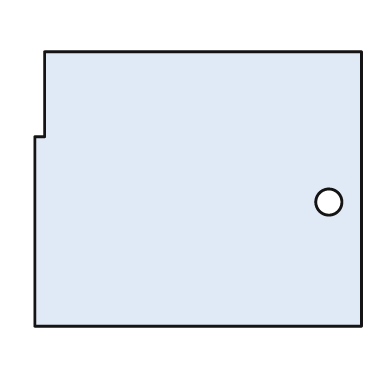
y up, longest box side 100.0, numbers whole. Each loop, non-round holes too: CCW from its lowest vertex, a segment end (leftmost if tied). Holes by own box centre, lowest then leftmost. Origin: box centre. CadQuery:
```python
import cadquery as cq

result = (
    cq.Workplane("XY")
    .moveTo(-50.0, -42.0)
    .lineTo(50.0, -42.0)
    .lineTo(50.0, 42.0)
    .lineTo(-47.0, 42.0)
    .lineTo(-47.0, 16.0)
    .lineTo(-50.0, 16.0)
    .close()
    .moveTo(40.0, -4.0)
    .circle(4.0)
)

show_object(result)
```